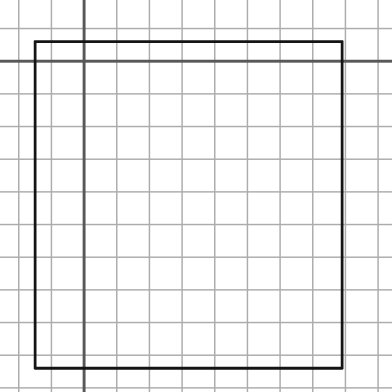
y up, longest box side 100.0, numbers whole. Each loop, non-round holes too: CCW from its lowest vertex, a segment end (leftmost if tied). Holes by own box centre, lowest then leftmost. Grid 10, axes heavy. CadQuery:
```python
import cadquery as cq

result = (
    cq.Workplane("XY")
    .moveTo(-15.0, -94.0)
    .lineTo(79.0, -94.0)
    .lineTo(79.0, 6.0)
    .lineTo(-15.0, 6.0)
    .close()
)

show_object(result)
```